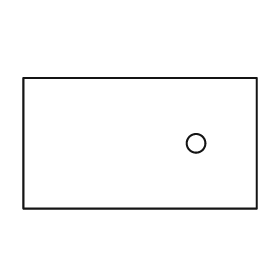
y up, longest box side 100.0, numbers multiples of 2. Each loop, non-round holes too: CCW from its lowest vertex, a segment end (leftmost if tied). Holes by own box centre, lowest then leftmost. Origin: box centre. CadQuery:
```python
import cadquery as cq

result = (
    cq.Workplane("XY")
    .moveTo(-50.0, -28.0)
    .lineTo(50.0, -28.0)
    .lineTo(50.0, 28.0)
    .lineTo(-50.0, 28.0)
    .close()
    .moveTo(24.0, 0.0)
    .circle(4.0)
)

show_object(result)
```